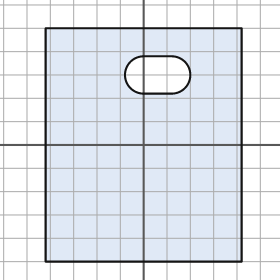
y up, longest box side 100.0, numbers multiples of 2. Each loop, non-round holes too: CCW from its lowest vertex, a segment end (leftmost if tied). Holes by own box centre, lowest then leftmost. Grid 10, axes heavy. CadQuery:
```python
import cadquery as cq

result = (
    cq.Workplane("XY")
    .moveTo(-42.0, -50.0)
    .lineTo(42.0, -50.0)
    .lineTo(42.0, 50.0)
    .lineTo(-42.0, 50.0)
    .close()
    .moveTo(0.0, 22.0)
    .lineTo(12.0, 22.0)
    .threePointArc((20.0, 30.0), (12.0, 38.0))
    .lineTo(0.0, 38.0)
    .threePointArc((-8.0, 30.0), (0.0, 22.0))
    .close()
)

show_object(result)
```